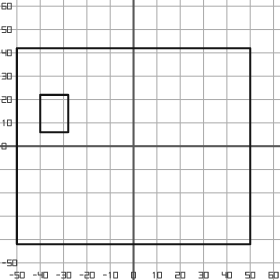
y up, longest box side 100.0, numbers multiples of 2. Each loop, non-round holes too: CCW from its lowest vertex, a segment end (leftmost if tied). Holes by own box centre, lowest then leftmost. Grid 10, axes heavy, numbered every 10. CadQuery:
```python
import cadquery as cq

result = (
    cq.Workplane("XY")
    .moveTo(-50.0, -42.0)
    .lineTo(50.0, -42.0)
    .lineTo(50.0, 42.0)
    .lineTo(-50.0, 42.0)
    .close()
    .moveTo(-40.0, 6.0)
    .lineTo(-28.0, 6.0)
    .lineTo(-28.0, 22.0)
    .lineTo(-40.0, 22.0)
    .close()
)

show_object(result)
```